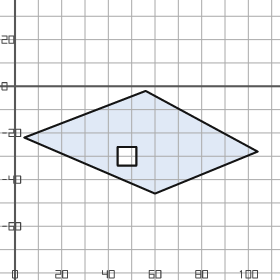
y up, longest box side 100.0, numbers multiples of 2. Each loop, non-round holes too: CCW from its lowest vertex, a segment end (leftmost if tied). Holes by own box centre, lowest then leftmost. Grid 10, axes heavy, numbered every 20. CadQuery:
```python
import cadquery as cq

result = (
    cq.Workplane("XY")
    .moveTo(60.0, -46.0)
    .lineTo(104.0, -28.0)
    .lineTo(56.0, -2.0)
    .lineTo(4.0, -22.0)
    .close()
    .moveTo(44.0, -34.0)
    .lineTo(52.0, -34.0)
    .lineTo(52.0, -26.0)
    .lineTo(44.0, -26.0)
    .close()
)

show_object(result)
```